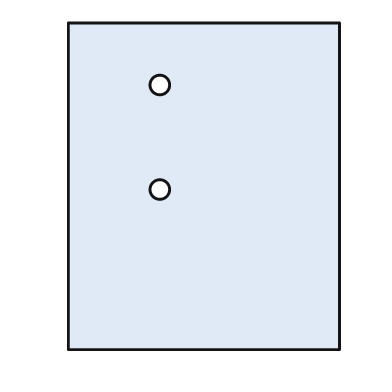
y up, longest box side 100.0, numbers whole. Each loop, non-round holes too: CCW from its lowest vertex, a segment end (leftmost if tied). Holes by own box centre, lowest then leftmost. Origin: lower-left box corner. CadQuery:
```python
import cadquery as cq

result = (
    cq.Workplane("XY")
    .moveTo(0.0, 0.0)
    .lineTo(83.0, 0.0)
    .lineTo(83.0, 100.0)
    .lineTo(0.0, 100.0)
    .close()
    .moveTo(28.0, 49.0)
    .circle(3.0)
    .moveTo(28.0, 81.0)
    .circle(3.0)
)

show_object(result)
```